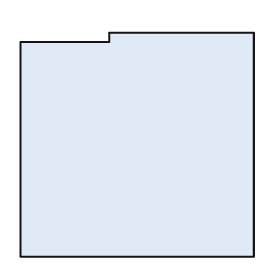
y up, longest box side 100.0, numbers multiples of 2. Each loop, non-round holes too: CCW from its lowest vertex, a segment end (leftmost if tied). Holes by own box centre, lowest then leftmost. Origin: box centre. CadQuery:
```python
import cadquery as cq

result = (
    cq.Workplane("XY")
    .moveTo(-50.0, -48.0)
    .lineTo(50.0, -48.0)
    .lineTo(50.0, 48.0)
    .lineTo(-12.0, 48.0)
    .lineTo(-12.0, 44.0)
    .lineTo(-50.0, 44.0)
    .close()
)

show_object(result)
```